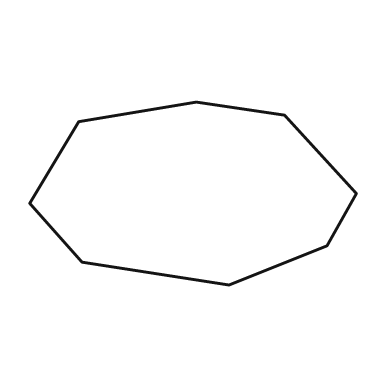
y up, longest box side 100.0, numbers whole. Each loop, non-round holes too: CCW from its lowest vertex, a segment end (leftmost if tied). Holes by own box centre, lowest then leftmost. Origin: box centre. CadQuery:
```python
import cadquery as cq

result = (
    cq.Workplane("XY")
    .moveTo(11.0, -28.0)
    .lineTo(41.0, -16.0)
    .lineTo(50.0, 0.0)
    .lineTo(28.0, 24.0)
    .lineTo(1.0, 28.0)
    .lineTo(-35.0, 22.0)
    .lineTo(-50.0, -3.0)
    .lineTo(-34.0, -21.0)
    .close()
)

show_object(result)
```